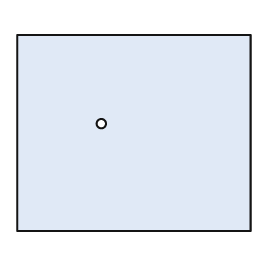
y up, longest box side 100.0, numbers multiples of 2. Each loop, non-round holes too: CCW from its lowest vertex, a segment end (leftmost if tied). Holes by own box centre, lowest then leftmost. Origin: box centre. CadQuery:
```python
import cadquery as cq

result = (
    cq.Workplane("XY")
    .moveTo(-50.0, -42.0)
    .lineTo(50.0, -42.0)
    .lineTo(50.0, 42.0)
    .lineTo(-50.0, 42.0)
    .close()
    .moveTo(-14.0, 4.0)
    .circle(2.0)
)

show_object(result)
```